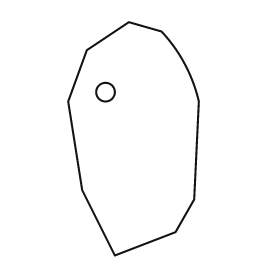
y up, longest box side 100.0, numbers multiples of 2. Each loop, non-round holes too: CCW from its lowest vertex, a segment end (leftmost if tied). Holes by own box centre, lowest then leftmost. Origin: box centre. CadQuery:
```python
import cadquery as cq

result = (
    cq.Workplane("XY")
    .moveTo(-8.0, -50.0)
    .lineTo(18.0, -40.0)
    .lineTo(26.0, -26.0)
    .lineTo(28.0, 16.0)
    .threePointArc((22.0, 32.0), (12.0, 46.0))
    .lineTo(-2.0, 50.0)
    .lineTo(-20.0, 38.0)
    .lineTo(-28.0, 16.0)
    .lineTo(-22.0, -22.0)
    .close()
    .moveTo(-12.0, 20.0)
    .circle(4.0)
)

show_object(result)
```